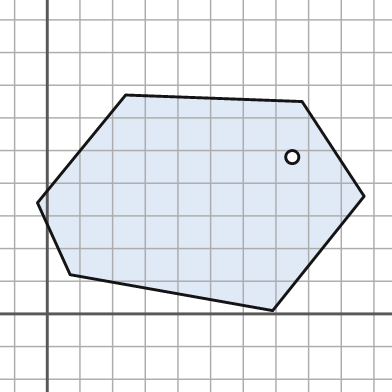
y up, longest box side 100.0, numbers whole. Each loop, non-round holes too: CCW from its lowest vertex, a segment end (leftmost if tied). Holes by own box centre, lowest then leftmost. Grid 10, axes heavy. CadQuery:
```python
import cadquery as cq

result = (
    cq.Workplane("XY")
    .moveTo(69.0, 1.0)
    .lineTo(97.0, 36.0)
    .lineTo(78.0, 65.0)
    .lineTo(24.0, 67.0)
    .lineTo(-3.0, 34.0)
    .lineTo(7.0, 12.0)
    .close()
    .moveTo(75.0, 48.0)
    .circle(2.0)
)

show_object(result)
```